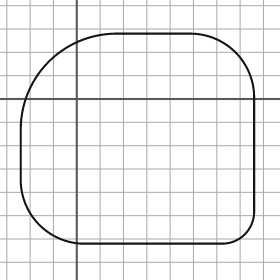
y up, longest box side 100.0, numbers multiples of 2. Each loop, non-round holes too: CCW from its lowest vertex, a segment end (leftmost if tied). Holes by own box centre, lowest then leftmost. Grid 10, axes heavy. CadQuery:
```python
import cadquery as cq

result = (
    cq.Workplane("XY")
    .moveTo(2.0, -62.0)
    .lineTo(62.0, -62.0)
    .threePointArc((72.0, -58.0), (76.0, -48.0))
    .lineTo(76.0, 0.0)
    .threePointArc((68.0, 20.0), (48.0, 28.0))
    .lineTo(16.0, 28.0)
    .threePointArc((-12.0, 16.0), (-24.0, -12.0))
    .lineTo(-24.0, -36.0)
    .threePointArc((-16.0, -54.0), (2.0, -62.0))
    .close()
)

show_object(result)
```